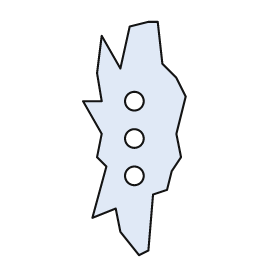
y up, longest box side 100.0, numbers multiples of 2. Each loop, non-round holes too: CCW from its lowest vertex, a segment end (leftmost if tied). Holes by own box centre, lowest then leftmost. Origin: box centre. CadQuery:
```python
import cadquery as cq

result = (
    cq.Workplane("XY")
    .moveTo(2.0, -50.0)
    .lineTo(6.0, -48.0)
    .lineTo(8.0, -24.0)
    .lineTo(14.0, -22.0)
    .lineTo(16.0, -14.0)
    .lineTo(20.0, -8.0)
    .lineTo(18.0, 2.0)
    .lineTo(22.0, 18.0)
    .lineTo(18.0, 26.0)
    .lineTo(12.0, 32.0)
    .lineTo(10.0, 50.0)
    .lineTo(6.0, 50.0)
    .lineTo(-2.0, 48.0)
    .lineTo(-6.0, 30.0)
    .lineTo(-14.0, 44.0)
    .lineTo(-16.0, 28.0)
    .lineTo(-14.0, 16.0)
    .lineTo(-22.0, 16.0)
    .lineTo(-14.0, 2.0)
    .lineTo(-16.0, -8.0)
    .lineTo(-12.0, -12.0)
    .lineTo(-18.0, -34.0)
    .lineTo(-8.0, -30.0)
    .lineTo(-6.0, -40.0)
    .close()
    .moveTo(0.0, -16.0)
    .circle(4.0)
    .moveTo(0.0, 0.0)
    .circle(4.0)
    .moveTo(0.0, 16.0)
    .circle(4.0)
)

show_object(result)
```